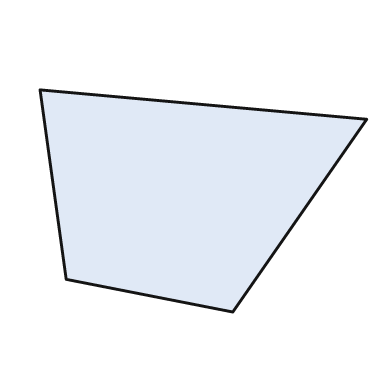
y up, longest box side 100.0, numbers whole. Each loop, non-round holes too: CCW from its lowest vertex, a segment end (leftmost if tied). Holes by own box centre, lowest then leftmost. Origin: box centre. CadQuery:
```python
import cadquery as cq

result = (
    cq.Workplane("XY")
    .moveTo(9.0, -34.0)
    .lineTo(50.0, 25.0)
    .lineTo(-50.0, 34.0)
    .lineTo(-42.0, -24.0)
    .close()
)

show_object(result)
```